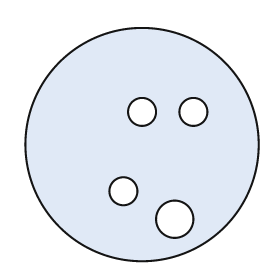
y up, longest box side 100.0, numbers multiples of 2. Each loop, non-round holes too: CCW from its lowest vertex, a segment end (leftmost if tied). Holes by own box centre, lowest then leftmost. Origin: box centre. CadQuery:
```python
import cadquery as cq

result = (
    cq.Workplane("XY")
    .moveTo(0.0, 0.0)
    .circle(50.0)
    .moveTo(14.0, -32.0)
    .circle(8.0)
    .moveTo(-8.0, -20.0)
    .circle(6.0)
    .moveTo(0.0, 14.0)
    .circle(6.0)
    .moveTo(22.0, 14.0)
    .circle(6.0)
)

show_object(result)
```